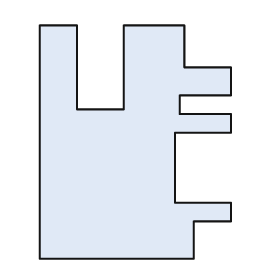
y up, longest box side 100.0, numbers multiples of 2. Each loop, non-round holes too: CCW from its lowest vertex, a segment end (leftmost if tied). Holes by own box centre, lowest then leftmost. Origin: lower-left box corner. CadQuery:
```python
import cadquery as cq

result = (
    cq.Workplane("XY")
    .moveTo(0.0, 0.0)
    .lineTo(66.0, 0.0)
    .lineTo(66.0, 16.0)
    .lineTo(82.0, 16.0)
    .lineTo(82.0, 24.0)
    .lineTo(58.0, 24.0)
    .lineTo(58.0, 54.0)
    .lineTo(82.0, 54.0)
    .lineTo(82.0, 62.0)
    .lineTo(60.0, 62.0)
    .lineTo(60.0, 70.0)
    .lineTo(82.0, 70.0)
    .lineTo(82.0, 82.0)
    .lineTo(62.0, 82.0)
    .lineTo(62.0, 100.0)
    .lineTo(36.0, 100.0)
    .lineTo(36.0, 64.0)
    .lineTo(16.0, 64.0)
    .lineTo(16.0, 100.0)
    .lineTo(0.0, 100.0)
    .close()
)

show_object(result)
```